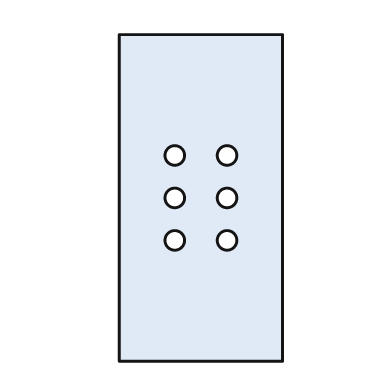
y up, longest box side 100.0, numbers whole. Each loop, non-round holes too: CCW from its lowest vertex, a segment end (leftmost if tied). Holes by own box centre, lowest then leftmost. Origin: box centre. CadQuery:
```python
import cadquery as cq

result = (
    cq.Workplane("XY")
    .moveTo(-25.0, -50.0)
    .lineTo(25.0, -50.0)
    .lineTo(25.0, 50.0)
    .lineTo(-25.0, 50.0)
    .close()
    .moveTo(-8.0, -13.0)
    .circle(3.0)
    .moveTo(8.0, -13.0)
    .circle(3.0)
    .moveTo(-8.0, 0.0)
    .circle(3.0)
    .moveTo(8.0, 0.0)
    .circle(3.0)
    .moveTo(-8.0, 13.0)
    .circle(3.0)
    .moveTo(8.0, 13.0)
    .circle(3.0)
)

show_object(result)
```